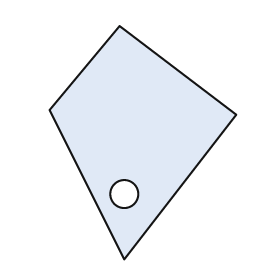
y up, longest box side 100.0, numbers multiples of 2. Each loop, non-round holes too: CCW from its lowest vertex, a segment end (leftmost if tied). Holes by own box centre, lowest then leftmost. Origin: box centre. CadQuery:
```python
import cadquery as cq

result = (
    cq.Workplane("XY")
    .moveTo(-8.0, -50.0)
    .lineTo(40.0, 12.0)
    .lineTo(-10.0, 50.0)
    .lineTo(-40.0, 14.0)
    .close()
    .moveTo(-8.0, -22.0)
    .circle(6.0)
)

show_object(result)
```